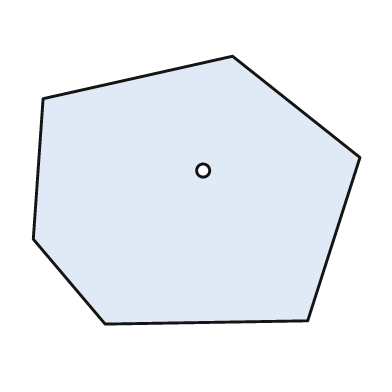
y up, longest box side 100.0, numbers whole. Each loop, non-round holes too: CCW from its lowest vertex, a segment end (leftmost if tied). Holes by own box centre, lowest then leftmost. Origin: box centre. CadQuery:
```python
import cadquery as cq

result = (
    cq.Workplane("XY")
    .moveTo(-28.0, -41.0)
    .lineTo(34.0, -40.0)
    .lineTo(50.0, 10.0)
    .lineTo(11.0, 41.0)
    .lineTo(-47.0, 28.0)
    .lineTo(-50.0, -15.0)
    .close()
    .moveTo(2.0, 6.0)
    .circle(2.0)
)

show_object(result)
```